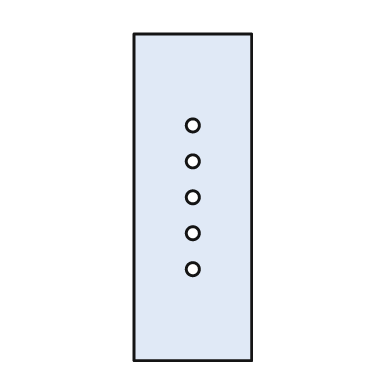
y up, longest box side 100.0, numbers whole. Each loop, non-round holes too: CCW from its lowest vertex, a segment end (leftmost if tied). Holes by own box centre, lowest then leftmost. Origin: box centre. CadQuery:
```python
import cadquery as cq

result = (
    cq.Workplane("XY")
    .moveTo(-18.0, -50.0)
    .lineTo(18.0, -50.0)
    .lineTo(18.0, 50.0)
    .lineTo(-18.0, 50.0)
    .close()
    .moveTo(0.0, -22.0)
    .circle(2.0)
    .moveTo(0.0, -11.0)
    .circle(2.0)
    .moveTo(0.0, 0.0)
    .circle(2.0)
    .moveTo(0.0, 11.0)
    .circle(2.0)
    .moveTo(0.0, 22.0)
    .circle(2.0)
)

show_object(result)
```